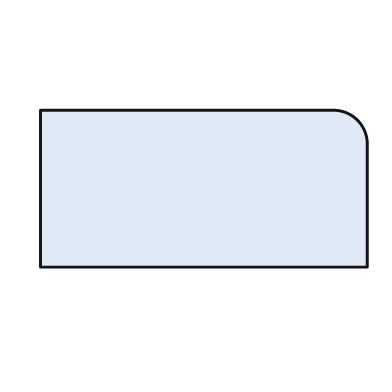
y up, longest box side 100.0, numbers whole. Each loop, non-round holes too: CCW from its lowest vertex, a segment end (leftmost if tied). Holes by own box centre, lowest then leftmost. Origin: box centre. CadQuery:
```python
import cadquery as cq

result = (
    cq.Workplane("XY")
    .moveTo(-50.0, -24.0)
    .lineTo(50.0, -24.0)
    .lineTo(50.0, 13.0)
    .threePointArc((47.0, 21.0), (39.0, 24.0))
    .lineTo(-50.0, 24.0)
    .close()
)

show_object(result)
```